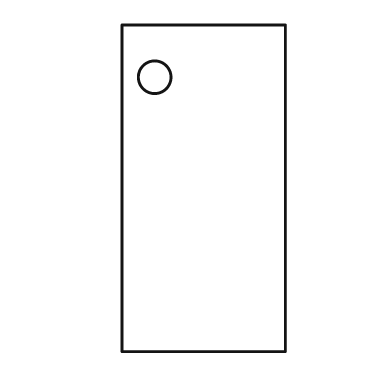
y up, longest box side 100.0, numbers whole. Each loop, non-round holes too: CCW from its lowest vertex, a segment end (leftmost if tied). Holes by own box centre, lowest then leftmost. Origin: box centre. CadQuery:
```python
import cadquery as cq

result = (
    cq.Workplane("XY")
    .moveTo(-25.0, -50.0)
    .lineTo(25.0, -50.0)
    .lineTo(25.0, 50.0)
    .lineTo(-25.0, 50.0)
    .close()
    .moveTo(-15.0, 34.0)
    .circle(5.0)
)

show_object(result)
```